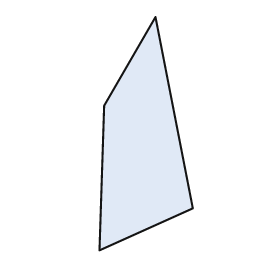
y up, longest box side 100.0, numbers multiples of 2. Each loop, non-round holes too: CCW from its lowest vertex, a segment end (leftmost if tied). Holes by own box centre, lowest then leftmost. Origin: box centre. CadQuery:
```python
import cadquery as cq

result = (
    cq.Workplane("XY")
    .moveTo(-20.0, -50.0)
    .lineTo(20.0, -32.0)
    .lineTo(4.0, 50.0)
    .lineTo(-18.0, 12.0)
    .close()
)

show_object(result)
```